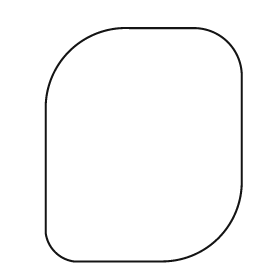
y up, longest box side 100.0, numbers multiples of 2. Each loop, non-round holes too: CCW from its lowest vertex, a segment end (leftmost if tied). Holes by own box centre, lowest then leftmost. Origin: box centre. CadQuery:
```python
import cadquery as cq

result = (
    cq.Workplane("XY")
    .moveTo(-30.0, -50.0)
    .lineTo(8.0, -50.0)
    .threePointArc((32.0, -40.0), (42.0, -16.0))
    .lineTo(42.0, 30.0)
    .threePointArc((36.0, 44.0), (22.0, 50.0))
    .lineTo(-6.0, 50.0)
    .threePointArc((-32.0, 40.0), (-42.0, 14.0))
    .lineTo(-42.0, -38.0)
    .threePointArc((-38.0, -46.0), (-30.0, -50.0))
    .close()
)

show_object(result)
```